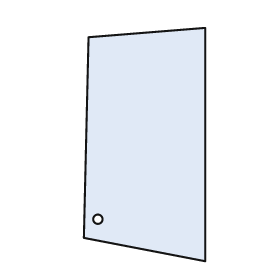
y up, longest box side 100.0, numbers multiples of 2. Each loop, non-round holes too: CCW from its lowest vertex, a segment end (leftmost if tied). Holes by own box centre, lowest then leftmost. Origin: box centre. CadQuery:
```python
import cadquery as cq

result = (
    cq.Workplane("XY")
    .moveTo(26.0, -50.0)
    .lineTo(26.0, 50.0)
    .lineTo(-24.0, 46.0)
    .lineTo(-26.0, -40.0)
    .close()
    .moveTo(-20.0, -32.0)
    .circle(2.0)
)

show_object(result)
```